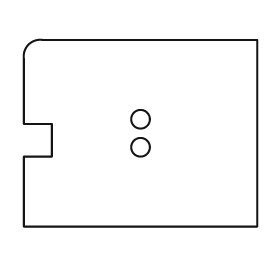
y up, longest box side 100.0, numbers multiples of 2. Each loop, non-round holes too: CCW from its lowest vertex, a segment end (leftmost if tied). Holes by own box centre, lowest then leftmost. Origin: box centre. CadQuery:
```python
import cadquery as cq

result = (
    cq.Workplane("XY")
    .moveTo(-50.0, -40.0)
    .lineTo(50.0, -40.0)
    .lineTo(50.0, 40.0)
    .lineTo(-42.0, 40.0)
    .threePointArc((-48.0, 38.0), (-50.0, 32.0))
    .lineTo(-50.0, 4.0)
    .lineTo(-38.0, 4.0)
    .lineTo(-38.0, -10.0)
    .lineTo(-50.0, -10.0)
    .close()
    .moveTo(0.0, -6.0)
    .circle(4.0)
    .moveTo(0.0, 6.0)
    .circle(4.0)
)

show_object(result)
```